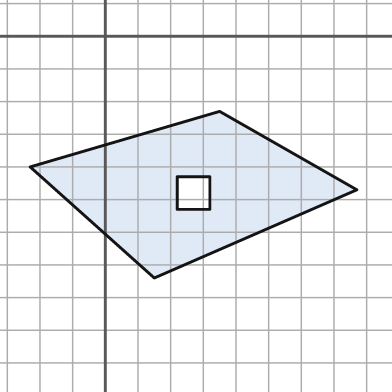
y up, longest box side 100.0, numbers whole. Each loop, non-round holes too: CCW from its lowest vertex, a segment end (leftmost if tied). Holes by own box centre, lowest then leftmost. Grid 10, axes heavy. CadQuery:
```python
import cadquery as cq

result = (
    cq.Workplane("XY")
    .moveTo(15.0, -74.0)
    .lineTo(77.0, -47.0)
    .lineTo(35.0, -23.0)
    .lineTo(-23.0, -40.0)
    .close()
    .moveTo(22.0, -53.0)
    .lineTo(32.0, -53.0)
    .lineTo(32.0, -43.0)
    .lineTo(22.0, -43.0)
    .close()
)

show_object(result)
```